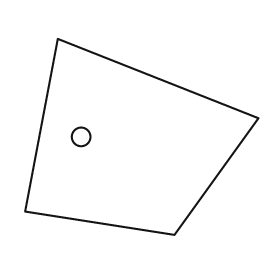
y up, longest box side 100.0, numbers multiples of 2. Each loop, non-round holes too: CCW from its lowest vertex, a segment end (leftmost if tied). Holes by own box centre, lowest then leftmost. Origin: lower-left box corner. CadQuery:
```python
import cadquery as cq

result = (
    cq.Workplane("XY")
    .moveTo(64.0, 0.0)
    .lineTo(100.0, 50.0)
    .lineTo(14.0, 84.0)
    .lineTo(0.0, 10.0)
    .close()
    .moveTo(24.0, 42.0)
    .circle(4.0)
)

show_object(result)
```